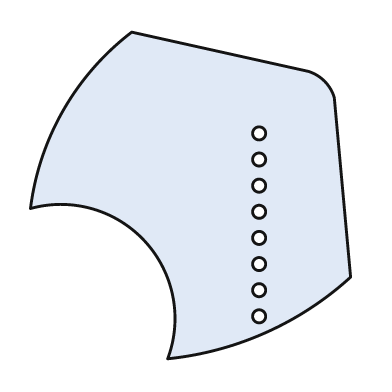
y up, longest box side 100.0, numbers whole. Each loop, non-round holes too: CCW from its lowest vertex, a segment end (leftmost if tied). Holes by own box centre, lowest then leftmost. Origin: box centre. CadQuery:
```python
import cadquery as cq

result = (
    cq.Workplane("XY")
    .moveTo(-7.0, -50.0)
    .threePointArc((23.0, -42.0), (49.0, -25.0))
    .lineTo(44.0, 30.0)
    .threePointArc((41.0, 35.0), (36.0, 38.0))
    .lineTo(-18.0, 50.0)
    .threePointArc((-39.0, 26.0), (-49.0, -4.0))
    .threePointArc((-14.0, -14.0), (-7.0, -50.0))
    .close()
    .moveTo(21.0, -37.0)
    .circle(2.0)
    .moveTo(21.0, -29.0)
    .circle(2.0)
    .moveTo(21.0, -21.0)
    .circle(2.0)
    .moveTo(21.0, -13.0)
    .circle(2.0)
    .moveTo(21.0, -5.0)
    .circle(2.0)
    .moveTo(21.0, 3.0)
    .circle(2.0)
    .moveTo(21.0, 11.0)
    .circle(2.0)
    .moveTo(21.0, 19.0)
    .circle(2.0)
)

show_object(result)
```